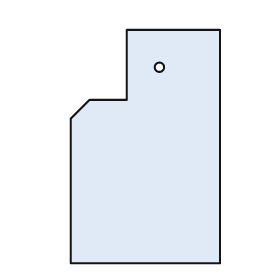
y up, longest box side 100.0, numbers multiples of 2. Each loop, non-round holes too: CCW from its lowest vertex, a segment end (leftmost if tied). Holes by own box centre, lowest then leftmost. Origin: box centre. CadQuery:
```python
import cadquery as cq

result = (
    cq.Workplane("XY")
    .moveTo(-32.0, -50.0)
    .lineTo(32.0, -50.0)
    .lineTo(32.0, 50.0)
    .lineTo(-8.0, 50.0)
    .lineTo(-8.0, 20.0)
    .lineTo(-24.0, 20.0)
    .lineTo(-32.0, 12.0)
    .close()
    .moveTo(6.0, 34.0)
    .circle(2.0)
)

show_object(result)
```